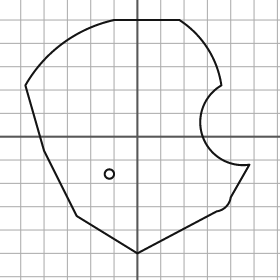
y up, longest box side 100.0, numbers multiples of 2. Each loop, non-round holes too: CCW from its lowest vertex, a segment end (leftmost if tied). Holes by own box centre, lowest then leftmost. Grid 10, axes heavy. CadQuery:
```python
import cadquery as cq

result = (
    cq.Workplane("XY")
    .moveTo(0.0, -50.0)
    .lineTo(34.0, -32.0)
    .threePointArc((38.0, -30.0), (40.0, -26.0))
    .lineTo(48.0, -12.0)
    .threePointArc((28.0, 0.0), (36.0, 22.0))
    .threePointArc((30.0, 38.0), (18.0, 50.0))
    .lineTo(-10.0, 50.0)
    .threePointArc((-32.0, 40.0), (-48.0, 22.0))
    .lineTo(-40.0, -6.0)
    .lineTo(-26.0, -34.0)
    .close()
    .moveTo(-12.0, -16.0)
    .circle(2.0)
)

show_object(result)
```